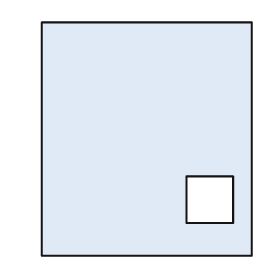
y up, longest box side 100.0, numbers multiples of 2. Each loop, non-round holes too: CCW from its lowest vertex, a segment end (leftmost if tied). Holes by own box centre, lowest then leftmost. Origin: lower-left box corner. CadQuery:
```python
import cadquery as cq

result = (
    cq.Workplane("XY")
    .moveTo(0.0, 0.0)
    .lineTo(90.0, 0.0)
    .lineTo(90.0, 100.0)
    .lineTo(0.0, 100.0)
    .close()
    .moveTo(62.0, 14.0)
    .lineTo(82.0, 14.0)
    .lineTo(82.0, 34.0)
    .lineTo(62.0, 34.0)
    .close()
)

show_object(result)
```